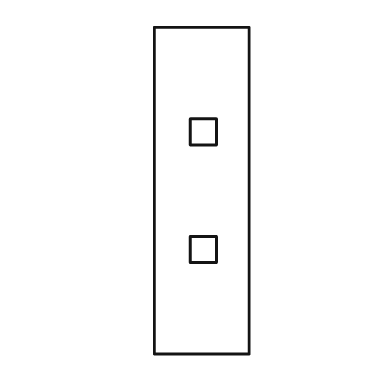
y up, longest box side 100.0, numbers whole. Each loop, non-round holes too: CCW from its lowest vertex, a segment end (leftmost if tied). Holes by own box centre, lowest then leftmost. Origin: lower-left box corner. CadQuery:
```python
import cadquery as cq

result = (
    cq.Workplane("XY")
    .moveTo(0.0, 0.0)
    .lineTo(29.0, 0.0)
    .lineTo(29.0, 100.0)
    .lineTo(0.0, 100.0)
    .close()
    .moveTo(11.0, 28.0)
    .lineTo(19.0, 28.0)
    .lineTo(19.0, 36.0)
    .lineTo(11.0, 36.0)
    .close()
    .moveTo(11.0, 64.0)
    .lineTo(19.0, 64.0)
    .lineTo(19.0, 72.0)
    .lineTo(11.0, 72.0)
    .close()
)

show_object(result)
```